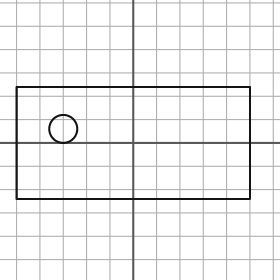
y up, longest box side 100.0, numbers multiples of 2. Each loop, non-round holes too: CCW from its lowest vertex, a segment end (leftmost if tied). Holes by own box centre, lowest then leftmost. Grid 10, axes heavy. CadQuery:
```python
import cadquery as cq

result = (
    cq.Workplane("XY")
    .moveTo(-50.0, -24.0)
    .lineTo(50.0, -24.0)
    .lineTo(50.0, 24.0)
    .lineTo(-50.0, 24.0)
    .close()
    .moveTo(-30.0, 6.0)
    .circle(6.0)
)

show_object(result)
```